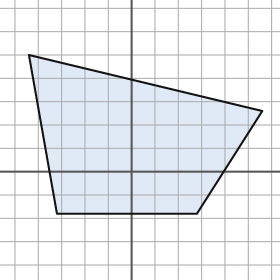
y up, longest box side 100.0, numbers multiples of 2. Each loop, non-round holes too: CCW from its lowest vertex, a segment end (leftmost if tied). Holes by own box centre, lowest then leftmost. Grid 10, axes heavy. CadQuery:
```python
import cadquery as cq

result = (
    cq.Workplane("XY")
    .moveTo(-32.0, -18.0)
    .lineTo(28.0, -18.0)
    .lineTo(56.0, 26.0)
    .lineTo(-44.0, 50.0)
    .close()
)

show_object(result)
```